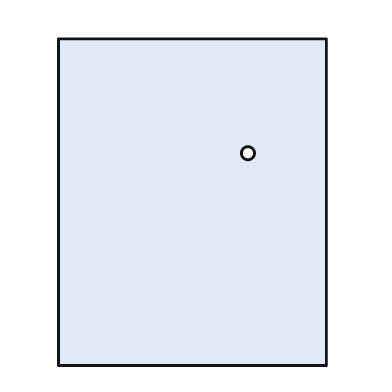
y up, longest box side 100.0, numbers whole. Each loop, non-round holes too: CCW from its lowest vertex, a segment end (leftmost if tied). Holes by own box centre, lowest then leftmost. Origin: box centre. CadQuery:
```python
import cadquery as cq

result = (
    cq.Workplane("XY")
    .moveTo(-41.0, -50.0)
    .lineTo(41.0, -50.0)
    .lineTo(41.0, 50.0)
    .lineTo(-41.0, 50.0)
    .close()
    .moveTo(17.0, 15.0)
    .circle(2.0)
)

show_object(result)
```